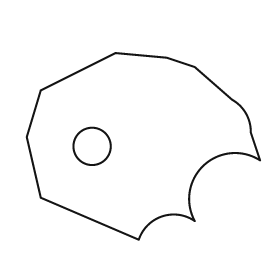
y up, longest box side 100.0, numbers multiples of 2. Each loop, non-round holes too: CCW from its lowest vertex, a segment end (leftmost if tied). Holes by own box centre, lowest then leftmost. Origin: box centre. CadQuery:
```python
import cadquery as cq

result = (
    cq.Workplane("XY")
    .moveTo(-2.0, -40.0)
    .threePointArc((8.0, -30.0), (22.0, -32.0))
    .threePointArc((26.0, -8.0), (50.0, -6.0))
    .lineTo(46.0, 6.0)
    .threePointArc((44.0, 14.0), (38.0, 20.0))
    .lineTo(22.0, 34.0)
    .lineTo(10.0, 38.0)
    .lineTo(-12.0, 40.0)
    .lineTo(-44.0, 24.0)
    .lineTo(-50.0, 4.0)
    .lineTo(-44.0, -22.0)
    .close()
    .moveTo(-22.0, 0.0)
    .circle(8.0)
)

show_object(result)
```